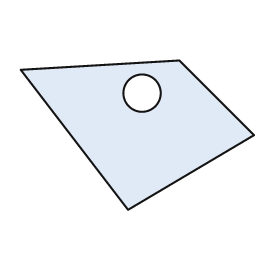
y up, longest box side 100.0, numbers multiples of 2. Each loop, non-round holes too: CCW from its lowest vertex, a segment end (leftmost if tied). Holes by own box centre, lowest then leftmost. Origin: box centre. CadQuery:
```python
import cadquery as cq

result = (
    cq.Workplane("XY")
    .moveTo(-4.0, -32.0)
    .lineTo(50.0, 0.0)
    .lineTo(18.0, 32.0)
    .lineTo(-50.0, 28.0)
    .close()
    .moveTo(2.0, 18.0)
    .circle(8.0)
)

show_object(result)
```